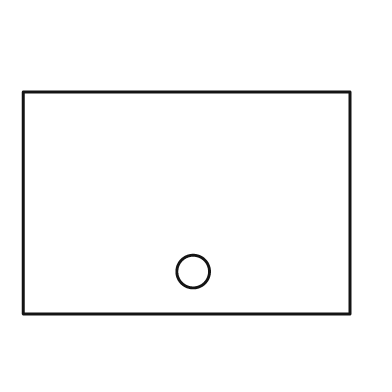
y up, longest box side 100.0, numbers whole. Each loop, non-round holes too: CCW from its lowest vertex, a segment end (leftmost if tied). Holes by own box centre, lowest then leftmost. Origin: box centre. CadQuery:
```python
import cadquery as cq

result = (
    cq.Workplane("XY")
    .moveTo(-50.0, -34.0)
    .lineTo(50.0, -34.0)
    .lineTo(50.0, 34.0)
    .lineTo(-50.0, 34.0)
    .close()
    .moveTo(2.0, -21.0)
    .circle(5.0)
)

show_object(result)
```